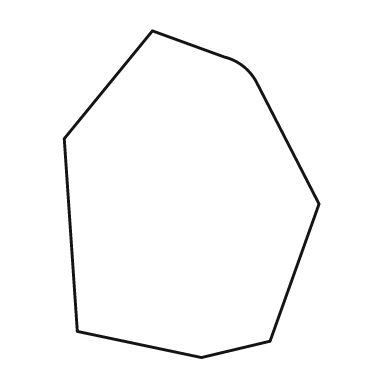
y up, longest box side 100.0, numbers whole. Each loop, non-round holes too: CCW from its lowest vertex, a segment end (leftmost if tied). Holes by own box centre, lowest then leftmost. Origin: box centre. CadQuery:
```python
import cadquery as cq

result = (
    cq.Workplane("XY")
    .moveTo(3.0, -50.0)
    .lineTo(24.0, -45.0)
    .lineTo(39.0, -3.0)
    .lineTo(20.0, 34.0)
    .threePointArc((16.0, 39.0), (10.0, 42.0))
    .lineTo(-12.0, 50.0)
    .lineTo(-39.0, 17.0)
    .lineTo(-35.0, -42.0)
    .close()
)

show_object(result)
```